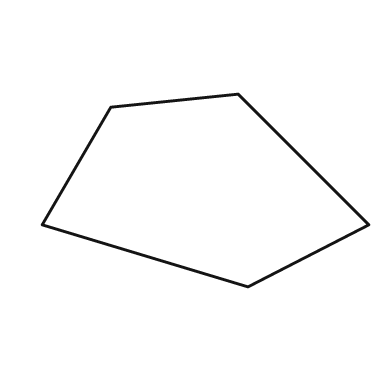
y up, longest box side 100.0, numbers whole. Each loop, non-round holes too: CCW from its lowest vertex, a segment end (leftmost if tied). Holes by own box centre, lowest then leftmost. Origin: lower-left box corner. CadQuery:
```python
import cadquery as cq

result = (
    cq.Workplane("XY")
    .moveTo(63.0, 0.0)
    .lineTo(100.0, 19.0)
    .lineTo(60.0, 59.0)
    .lineTo(21.0, 55.0)
    .lineTo(0.0, 19.0)
    .close()
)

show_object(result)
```